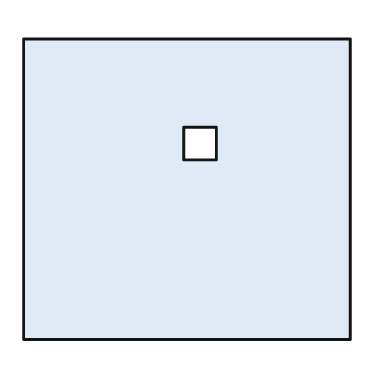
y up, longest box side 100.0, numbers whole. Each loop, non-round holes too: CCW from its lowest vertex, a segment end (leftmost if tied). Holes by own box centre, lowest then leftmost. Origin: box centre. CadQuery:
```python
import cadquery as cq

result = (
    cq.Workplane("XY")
    .moveTo(-50.0, -46.0)
    .lineTo(50.0, -46.0)
    .lineTo(50.0, 46.0)
    .lineTo(-50.0, 46.0)
    .close()
    .moveTo(-1.0, 9.0)
    .lineTo(9.0, 9.0)
    .lineTo(9.0, 19.0)
    .lineTo(-1.0, 19.0)
    .close()
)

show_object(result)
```